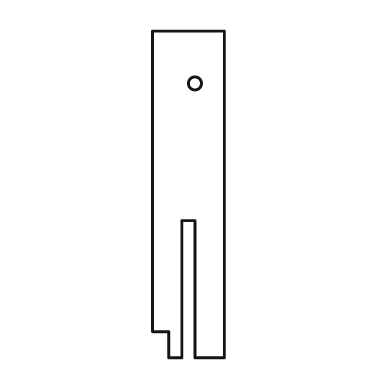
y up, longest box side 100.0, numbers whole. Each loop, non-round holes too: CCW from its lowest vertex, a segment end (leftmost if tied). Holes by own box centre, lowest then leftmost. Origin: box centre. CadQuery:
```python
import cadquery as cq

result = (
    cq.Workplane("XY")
    .moveTo(-6.0, -50.0)
    .lineTo(-2.0, -50.0)
    .lineTo(-2.0, -8.0)
    .lineTo(2.0, -8.0)
    .lineTo(2.0, -50.0)
    .lineTo(11.0, -50.0)
    .lineTo(11.0, 50.0)
    .lineTo(-11.0, 50.0)
    .lineTo(-11.0, -42.0)
    .lineTo(-6.0, -42.0)
    .close()
    .moveTo(2.0, 34.0)
    .circle(2.0)
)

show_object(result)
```